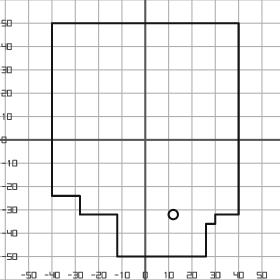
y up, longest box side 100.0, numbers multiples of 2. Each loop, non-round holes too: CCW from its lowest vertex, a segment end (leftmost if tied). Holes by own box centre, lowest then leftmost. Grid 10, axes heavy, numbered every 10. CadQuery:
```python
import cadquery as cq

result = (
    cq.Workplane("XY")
    .moveTo(-12.0, -50.0)
    .lineTo(26.0, -50.0)
    .lineTo(26.0, -36.0)
    .lineTo(30.0, -36.0)
    .lineTo(30.0, -32.0)
    .lineTo(40.0, -32.0)
    .lineTo(40.0, 50.0)
    .lineTo(-40.0, 50.0)
    .lineTo(-40.0, -24.0)
    .lineTo(-28.0, -24.0)
    .lineTo(-28.0, -32.0)
    .lineTo(-12.0, -32.0)
    .close()
    .moveTo(12.0, -32.0)
    .circle(2.0)
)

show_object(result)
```